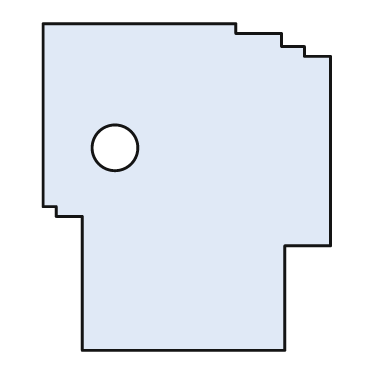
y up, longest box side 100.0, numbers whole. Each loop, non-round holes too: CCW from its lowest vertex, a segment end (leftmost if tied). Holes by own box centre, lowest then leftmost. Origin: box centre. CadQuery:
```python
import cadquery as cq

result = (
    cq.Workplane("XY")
    .moveTo(-32.0, -50.0)
    .lineTo(30.0, -50.0)
    .lineTo(30.0, -18.0)
    .lineTo(44.0, -18.0)
    .lineTo(44.0, 40.0)
    .lineTo(36.0, 40.0)
    .lineTo(36.0, 43.0)
    .lineTo(29.0, 43.0)
    .lineTo(29.0, 47.0)
    .lineTo(15.0, 47.0)
    .lineTo(15.0, 50.0)
    .lineTo(-44.0, 50.0)
    .lineTo(-44.0, -6.0)
    .lineTo(-40.0, -6.0)
    .lineTo(-40.0, -9.0)
    .lineTo(-32.0, -9.0)
    .close()
    .moveTo(-22.0, 12.0)
    .circle(7.0)
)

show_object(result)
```